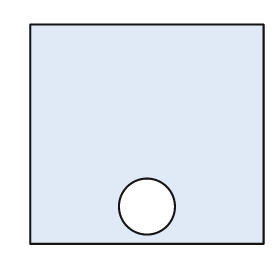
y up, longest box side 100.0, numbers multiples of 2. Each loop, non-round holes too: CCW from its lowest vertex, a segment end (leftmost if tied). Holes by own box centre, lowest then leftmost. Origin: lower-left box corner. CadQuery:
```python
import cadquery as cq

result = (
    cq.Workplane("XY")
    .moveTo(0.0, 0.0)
    .lineTo(100.0, 0.0)
    .lineTo(100.0, 94.0)
    .lineTo(0.0, 94.0)
    .close()
    .moveTo(50.0, 16.0)
    .circle(12.0)
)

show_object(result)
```